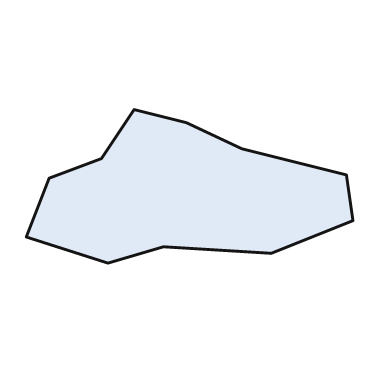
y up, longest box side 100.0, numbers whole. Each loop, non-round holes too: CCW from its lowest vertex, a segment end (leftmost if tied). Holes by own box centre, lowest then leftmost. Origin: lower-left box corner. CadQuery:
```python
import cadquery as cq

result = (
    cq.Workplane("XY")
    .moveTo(25.0, 0.0)
    .lineTo(42.0, 5.0)
    .lineTo(75.0, 3.0)
    .lineTo(100.0, 13.0)
    .lineTo(98.0, 27.0)
    .lineTo(66.0, 35.0)
    .lineTo(49.0, 43.0)
    .lineTo(33.0, 47.0)
    .lineTo(23.0, 32.0)
    .lineTo(7.0, 26.0)
    .lineTo(0.0, 8.0)
    .close()
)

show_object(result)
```